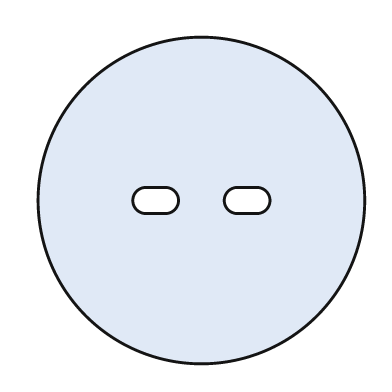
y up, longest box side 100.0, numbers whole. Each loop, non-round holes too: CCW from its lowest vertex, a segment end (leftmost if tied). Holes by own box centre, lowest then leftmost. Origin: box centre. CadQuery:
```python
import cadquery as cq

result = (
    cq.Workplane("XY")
    .moveTo(0.0, 0.0)
    .circle(50.0)
    .moveTo(-17.0, -4.0)
    .lineTo(-11.0, -4.0)
    .threePointArc((-7.0, 0.0), (-11.0, 4.0))
    .lineTo(-17.0, 4.0)
    .threePointArc((-21.0, 0.0), (-17.0, -4.0))
    .close()
    .moveTo(11.0, -4.0)
    .lineTo(17.0, -4.0)
    .threePointArc((21.0, 0.0), (17.0, 4.0))
    .lineTo(11.0, 4.0)
    .threePointArc((7.0, 0.0), (11.0, -4.0))
    .close()
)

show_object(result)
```